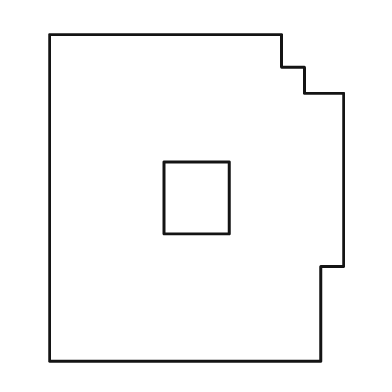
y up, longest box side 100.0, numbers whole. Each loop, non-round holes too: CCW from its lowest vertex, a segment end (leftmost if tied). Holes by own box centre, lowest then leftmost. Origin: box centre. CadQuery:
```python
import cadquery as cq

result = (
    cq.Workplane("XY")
    .moveTo(-45.0, -50.0)
    .lineTo(38.0, -50.0)
    .lineTo(38.0, -21.0)
    .lineTo(45.0, -21.0)
    .lineTo(45.0, 32.0)
    .lineTo(33.0, 32.0)
    .lineTo(33.0, 40.0)
    .lineTo(26.0, 40.0)
    .lineTo(26.0, 50.0)
    .lineTo(-45.0, 50.0)
    .close()
    .moveTo(-10.0, -11.0)
    .lineTo(10.0, -11.0)
    .lineTo(10.0, 11.0)
    .lineTo(-10.0, 11.0)
    .close()
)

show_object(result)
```